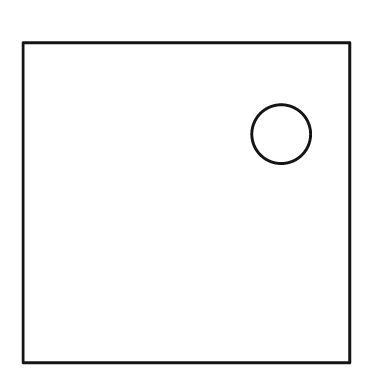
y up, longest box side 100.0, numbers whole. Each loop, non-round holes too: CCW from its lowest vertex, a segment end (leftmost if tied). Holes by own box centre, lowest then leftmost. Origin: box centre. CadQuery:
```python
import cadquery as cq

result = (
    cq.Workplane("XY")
    .moveTo(-50.0, -49.0)
    .lineTo(50.0, -49.0)
    .lineTo(50.0, 49.0)
    .lineTo(-50.0, 49.0)
    .close()
    .moveTo(29.0, 21.0)
    .circle(9.0)
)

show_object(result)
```